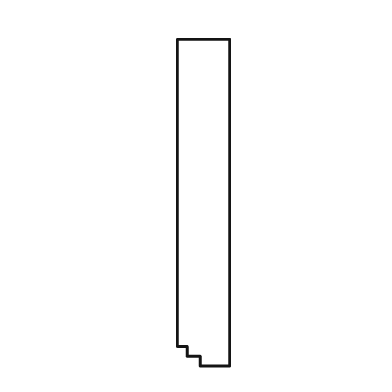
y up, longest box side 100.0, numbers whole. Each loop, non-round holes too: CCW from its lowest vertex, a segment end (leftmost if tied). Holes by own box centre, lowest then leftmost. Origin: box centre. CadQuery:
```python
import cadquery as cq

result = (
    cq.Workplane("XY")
    .moveTo(-1.0, -50.0)
    .lineTo(8.0, -50.0)
    .lineTo(8.0, 50.0)
    .lineTo(-8.0, 50.0)
    .lineTo(-8.0, -44.0)
    .lineTo(-5.0, -44.0)
    .lineTo(-5.0, -47.0)
    .lineTo(-1.0, -47.0)
    .close()
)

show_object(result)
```